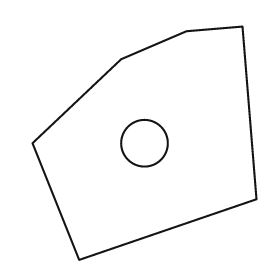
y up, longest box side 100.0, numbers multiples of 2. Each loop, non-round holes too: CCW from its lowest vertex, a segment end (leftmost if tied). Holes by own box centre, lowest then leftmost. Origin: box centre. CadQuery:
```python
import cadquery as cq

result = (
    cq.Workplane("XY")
    .moveTo(-28.0, -50.0)
    .lineTo(48.0, -24.0)
    .lineTo(42.0, 50.0)
    .lineTo(18.0, 48.0)
    .lineTo(-10.0, 36.0)
    .lineTo(-48.0, 0.0)
    .close()
    .moveTo(0.0, 0.0)
    .circle(10.0)
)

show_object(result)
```